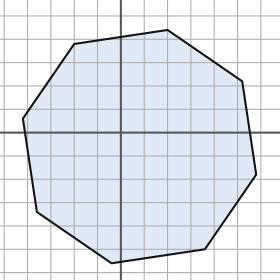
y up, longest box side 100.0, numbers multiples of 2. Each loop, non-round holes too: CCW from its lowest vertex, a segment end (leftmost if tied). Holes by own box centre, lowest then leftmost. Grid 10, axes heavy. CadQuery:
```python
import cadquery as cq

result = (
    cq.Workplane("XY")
    .moveTo(-4.0, -56.0)
    .lineTo(36.0, -50.0)
    .lineTo(58.0, -18.0)
    .lineTo(52.0, 22.0)
    .lineTo(20.0, 44.0)
    .lineTo(-20.0, 38.0)
    .lineTo(-42.0, 6.0)
    .lineTo(-36.0, -34.0)
    .close()
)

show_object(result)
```